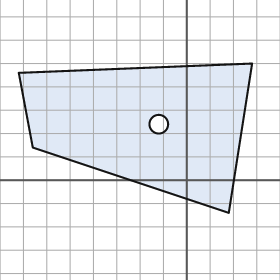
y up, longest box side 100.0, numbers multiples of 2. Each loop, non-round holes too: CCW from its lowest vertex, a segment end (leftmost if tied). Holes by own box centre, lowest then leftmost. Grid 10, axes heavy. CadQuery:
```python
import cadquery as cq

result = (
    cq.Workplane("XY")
    .moveTo(18.0, -14.0)
    .lineTo(28.0, 50.0)
    .lineTo(-72.0, 46.0)
    .lineTo(-66.0, 14.0)
    .close()
    .moveTo(-12.0, 24.0)
    .circle(4.0)
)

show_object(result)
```